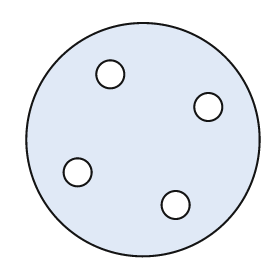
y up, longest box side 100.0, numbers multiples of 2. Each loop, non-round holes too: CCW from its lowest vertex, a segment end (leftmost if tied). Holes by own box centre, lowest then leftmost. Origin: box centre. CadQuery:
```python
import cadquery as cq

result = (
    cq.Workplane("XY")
    .moveTo(0.0, 0.0)
    .circle(50.0)
    .moveTo(14.0, -28.0)
    .circle(6.0)
    .moveTo(-28.0, -14.0)
    .circle(6.0)
    .moveTo(28.0, 14.0)
    .circle(6.0)
    .moveTo(-14.0, 28.0)
    .circle(6.0)
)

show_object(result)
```